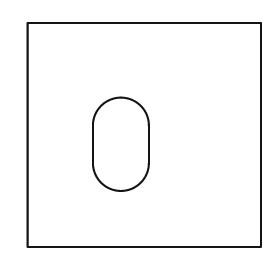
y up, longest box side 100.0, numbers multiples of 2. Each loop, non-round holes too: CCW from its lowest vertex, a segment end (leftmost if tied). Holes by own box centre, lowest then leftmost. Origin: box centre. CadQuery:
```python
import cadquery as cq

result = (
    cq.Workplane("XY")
    .moveTo(-50.0, -48.0)
    .lineTo(50.0, -48.0)
    .lineTo(50.0, 48.0)
    .lineTo(-50.0, 48.0)
    .close()
    .moveTo(-22.0, -12.0)
    .threePointArc((-10.0, -24.0), (2.0, -12.0))
    .lineTo(2.0, 4.0)
    .threePointArc((-10.0, 16.0), (-22.0, 4.0))
    .close()
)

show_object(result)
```